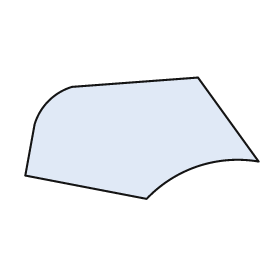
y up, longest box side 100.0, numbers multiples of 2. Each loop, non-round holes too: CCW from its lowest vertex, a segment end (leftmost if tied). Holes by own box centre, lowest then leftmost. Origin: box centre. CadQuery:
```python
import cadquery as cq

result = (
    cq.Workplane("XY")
    .moveTo(2.0, -26.0)
    .threePointArc((24.0, -12.0), (50.0, -10.0))
    .lineTo(24.0, 26.0)
    .lineTo(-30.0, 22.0)
    .threePointArc((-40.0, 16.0), (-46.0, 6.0))
    .lineTo(-50.0, -16.0)
    .close()
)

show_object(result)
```